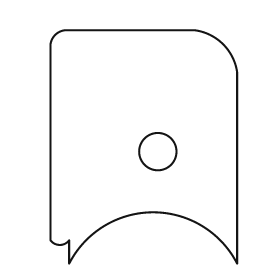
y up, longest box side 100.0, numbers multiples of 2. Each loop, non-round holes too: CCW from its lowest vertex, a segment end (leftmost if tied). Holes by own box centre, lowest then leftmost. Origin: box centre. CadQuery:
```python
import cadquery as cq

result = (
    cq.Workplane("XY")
    .moveTo(-32.0, -50.0)
    .threePointArc((4.0, -28.0), (40.0, -50.0))
    .lineTo(40.0, 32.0)
    .threePointArc((34.0, 44.0), (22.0, 50.0))
    .lineTo(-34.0, 50.0)
    .threePointArc((-38.0, 48.0), (-40.0, 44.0))
    .lineTo(-40.0, -40.0)
    .threePointArc((-36.0, -42.0), (-32.0, -40.0))
    .close()
    .moveTo(6.0, -2.0)
    .circle(8.0)
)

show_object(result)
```